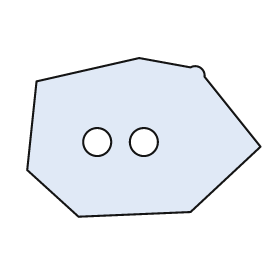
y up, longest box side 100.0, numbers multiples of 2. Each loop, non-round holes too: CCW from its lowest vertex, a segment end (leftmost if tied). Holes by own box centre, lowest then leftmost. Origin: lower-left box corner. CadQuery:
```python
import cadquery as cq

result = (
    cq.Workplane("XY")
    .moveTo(22.0, 0.0)
    .lineTo(70.0, 2.0)
    .lineTo(100.0, 30.0)
    .lineTo(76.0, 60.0)
    .threePointArc((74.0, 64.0), (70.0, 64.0))
    .lineTo(48.0, 68.0)
    .lineTo(4.0, 58.0)
    .lineTo(0.0, 20.0)
    .close()
    .moveTo(30.0, 32.0)
    .circle(6.0)
    .moveTo(50.0, 32.0)
    .circle(6.0)
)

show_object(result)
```